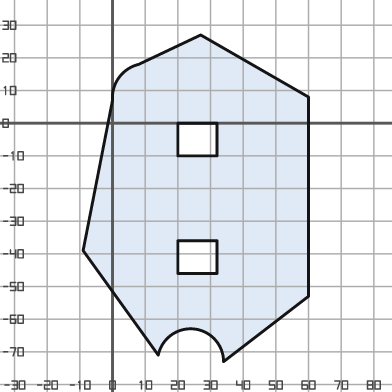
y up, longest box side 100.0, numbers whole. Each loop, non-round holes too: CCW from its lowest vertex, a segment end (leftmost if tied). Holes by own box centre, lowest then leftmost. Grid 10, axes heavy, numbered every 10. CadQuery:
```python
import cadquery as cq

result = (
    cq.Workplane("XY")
    .moveTo(34.0, -73.0)
    .lineTo(60.0, -53.0)
    .lineTo(60.0, 8.0)
    .lineTo(27.0, 27.0)
    .lineTo(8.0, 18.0)
    .threePointArc((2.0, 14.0), (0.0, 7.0))
    .lineTo(-9.0, -39.0)
    .lineTo(14.0, -71.0)
    .threePointArc((25.0, -63.0), (34.0, -73.0))
    .close()
    .moveTo(20.0, -46.0)
    .lineTo(32.0, -46.0)
    .lineTo(32.0, -36.0)
    .lineTo(20.0, -36.0)
    .close()
    .moveTo(20.0, -10.0)
    .lineTo(32.0, -10.0)
    .lineTo(32.0, 0.0)
    .lineTo(20.0, 0.0)
    .close()
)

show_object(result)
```